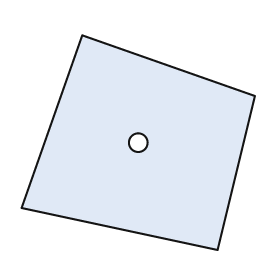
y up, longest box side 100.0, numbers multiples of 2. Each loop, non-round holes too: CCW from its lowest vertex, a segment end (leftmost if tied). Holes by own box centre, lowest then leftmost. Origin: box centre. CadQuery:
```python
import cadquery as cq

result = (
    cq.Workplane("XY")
    .moveTo(34.0, -46.0)
    .lineTo(50.0, 20.0)
    .lineTo(-24.0, 46.0)
    .lineTo(-50.0, -28.0)
    .close()
    .moveTo(0.0, 0.0)
    .circle(4.0)
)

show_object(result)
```